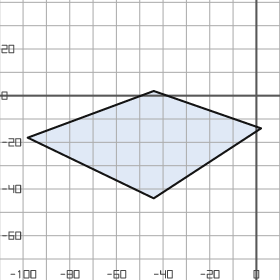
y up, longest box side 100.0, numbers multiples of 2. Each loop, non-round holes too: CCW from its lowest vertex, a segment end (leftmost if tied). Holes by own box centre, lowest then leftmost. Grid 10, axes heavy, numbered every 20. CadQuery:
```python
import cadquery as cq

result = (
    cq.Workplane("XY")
    .moveTo(-44.0, -44.0)
    .lineTo(2.0, -14.0)
    .lineTo(-44.0, 2.0)
    .lineTo(-98.0, -18.0)
    .close()
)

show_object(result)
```